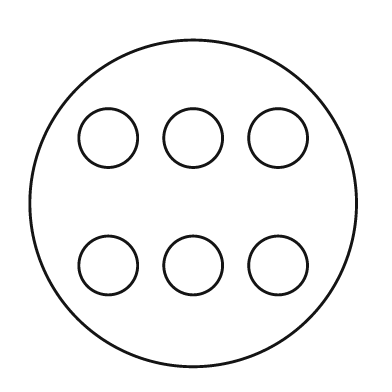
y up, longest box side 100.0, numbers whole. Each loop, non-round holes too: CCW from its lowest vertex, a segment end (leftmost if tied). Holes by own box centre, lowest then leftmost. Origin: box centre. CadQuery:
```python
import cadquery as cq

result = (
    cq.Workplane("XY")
    .moveTo(0.0, 0.0)
    .circle(50.0)
    .moveTo(-26.0, -19.0)
    .circle(9.0)
    .moveTo(0.0, -19.0)
    .circle(9.0)
    .moveTo(26.0, -19.0)
    .circle(9.0)
    .moveTo(-26.0, 20.0)
    .circle(9.0)
    .moveTo(0.0, 20.0)
    .circle(9.0)
    .moveTo(26.0, 20.0)
    .circle(9.0)
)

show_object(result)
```